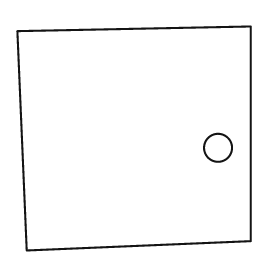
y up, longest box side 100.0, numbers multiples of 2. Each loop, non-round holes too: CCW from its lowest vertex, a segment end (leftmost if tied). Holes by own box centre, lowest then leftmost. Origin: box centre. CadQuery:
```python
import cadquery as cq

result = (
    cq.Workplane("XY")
    .moveTo(-46.0, -48.0)
    .lineTo(50.0, -44.0)
    .lineTo(50.0, 48.0)
    .lineTo(-50.0, 46.0)
    .close()
    .moveTo(36.0, -4.0)
    .circle(6.0)
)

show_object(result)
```